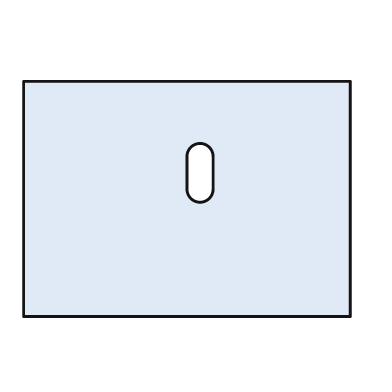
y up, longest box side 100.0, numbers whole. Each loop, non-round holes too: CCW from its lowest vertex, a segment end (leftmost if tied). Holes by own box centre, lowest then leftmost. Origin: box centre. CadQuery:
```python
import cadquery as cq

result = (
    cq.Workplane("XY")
    .moveTo(-50.0, -36.0)
    .lineTo(50.0, -36.0)
    .lineTo(50.0, 36.0)
    .lineTo(-50.0, 36.0)
    .close()
    .moveTo(0.0, 3.0)
    .threePointArc((4.0, -1.0), (8.0, 3.0))
    .lineTo(8.0, 13.0)
    .threePointArc((4.0, 17.0), (0.0, 13.0))
    .close()
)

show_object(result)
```